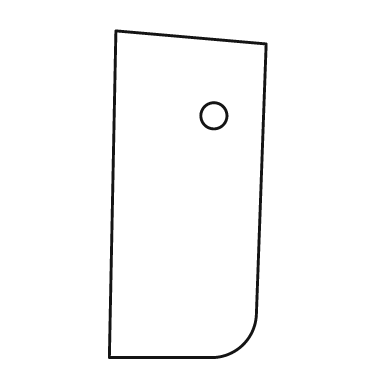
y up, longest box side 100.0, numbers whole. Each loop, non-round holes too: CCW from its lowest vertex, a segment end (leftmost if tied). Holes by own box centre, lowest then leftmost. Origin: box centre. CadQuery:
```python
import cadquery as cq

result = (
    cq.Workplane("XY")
    .moveTo(-24.0, -50.0)
    .lineTo(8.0, -50.0)
    .threePointArc((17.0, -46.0), (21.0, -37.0))
    .lineTo(24.0, 46.0)
    .lineTo(-22.0, 50.0)
    .close()
    .moveTo(8.0, 24.0)
    .circle(4.0)
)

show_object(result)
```